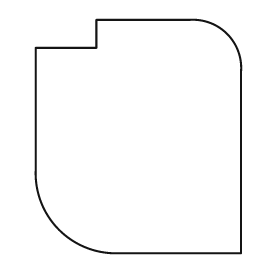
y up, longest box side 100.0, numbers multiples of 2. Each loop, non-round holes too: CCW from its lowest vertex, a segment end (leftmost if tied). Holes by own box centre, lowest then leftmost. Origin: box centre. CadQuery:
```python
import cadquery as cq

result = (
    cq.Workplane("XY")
    .moveTo(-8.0, -50.0)
    .lineTo(44.0, -50.0)
    .lineTo(44.0, 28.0)
    .threePointArc((38.0, 44.0), (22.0, 50.0))
    .lineTo(-18.0, 50.0)
    .lineTo(-18.0, 38.0)
    .lineTo(-44.0, 38.0)
    .lineTo(-44.0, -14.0)
    .threePointArc((-34.0, -40.0), (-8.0, -50.0))
    .close()
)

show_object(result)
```